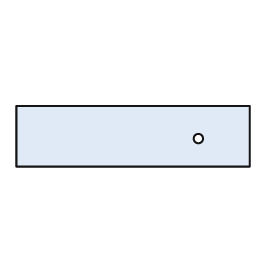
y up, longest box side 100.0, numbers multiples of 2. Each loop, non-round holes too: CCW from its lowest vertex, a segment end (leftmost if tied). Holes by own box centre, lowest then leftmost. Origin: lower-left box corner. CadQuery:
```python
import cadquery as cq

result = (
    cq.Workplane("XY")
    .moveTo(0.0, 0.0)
    .lineTo(100.0, 0.0)
    .lineTo(100.0, 26.0)
    .lineTo(0.0, 26.0)
    .close()
    .moveTo(78.0, 12.0)
    .circle(2.0)
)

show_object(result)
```